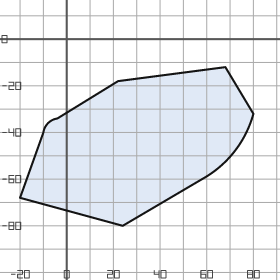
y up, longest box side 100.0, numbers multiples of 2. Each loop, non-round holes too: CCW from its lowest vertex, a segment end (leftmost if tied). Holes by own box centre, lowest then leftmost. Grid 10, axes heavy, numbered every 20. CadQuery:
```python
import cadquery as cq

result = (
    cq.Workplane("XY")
    .moveTo(24.0, -80.0)
    .lineTo(58.0, -60.0)
    .threePointArc((72.0, -48.0), (80.0, -32.0))
    .lineTo(68.0, -12.0)
    .lineTo(22.0, -18.0)
    .lineTo(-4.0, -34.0)
    .threePointArc((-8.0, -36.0), (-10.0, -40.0))
    .lineTo(-20.0, -68.0)
    .close()
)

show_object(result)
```